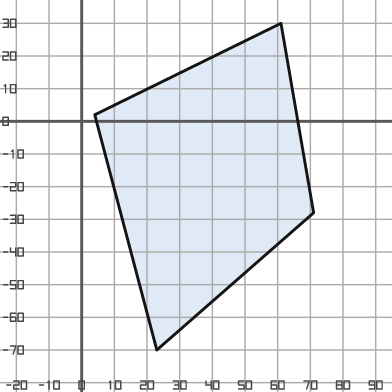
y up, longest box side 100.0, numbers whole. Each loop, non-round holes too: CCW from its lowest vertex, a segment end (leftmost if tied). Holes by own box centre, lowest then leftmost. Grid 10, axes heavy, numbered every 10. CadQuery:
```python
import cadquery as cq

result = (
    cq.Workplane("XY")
    .moveTo(23.0, -70.0)
    .lineTo(71.0, -28.0)
    .lineTo(61.0, 30.0)
    .lineTo(4.0, 2.0)
    .close()
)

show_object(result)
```